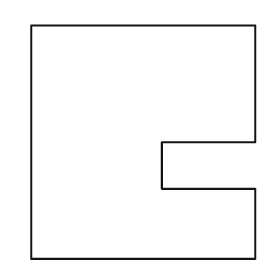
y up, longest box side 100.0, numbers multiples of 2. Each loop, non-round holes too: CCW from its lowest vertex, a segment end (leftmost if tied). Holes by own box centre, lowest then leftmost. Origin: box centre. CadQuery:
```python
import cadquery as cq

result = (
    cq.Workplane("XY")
    .moveTo(-48.0, -50.0)
    .lineTo(48.0, -50.0)
    .lineTo(48.0, -20.0)
    .lineTo(8.0, -20.0)
    .lineTo(8.0, 0.0)
    .lineTo(48.0, 0.0)
    .lineTo(48.0, 50.0)
    .lineTo(-48.0, 50.0)
    .close()
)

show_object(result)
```